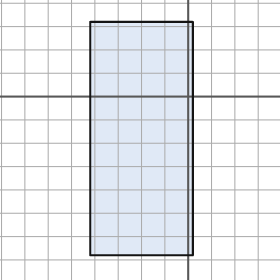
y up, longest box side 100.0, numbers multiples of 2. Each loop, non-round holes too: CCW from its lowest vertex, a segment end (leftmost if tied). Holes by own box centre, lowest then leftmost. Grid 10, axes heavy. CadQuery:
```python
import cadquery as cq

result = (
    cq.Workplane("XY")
    .moveTo(-42.0, -68.0)
    .lineTo(2.0, -68.0)
    .lineTo(2.0, 32.0)
    .lineTo(-42.0, 32.0)
    .close()
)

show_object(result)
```